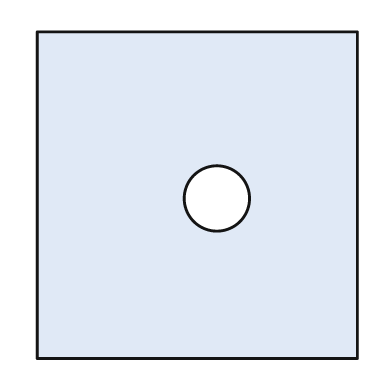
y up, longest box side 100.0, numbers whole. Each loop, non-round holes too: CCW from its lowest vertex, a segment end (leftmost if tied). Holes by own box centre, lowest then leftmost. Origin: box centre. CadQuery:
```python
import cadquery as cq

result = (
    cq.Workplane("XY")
    .moveTo(-49.0, -50.0)
    .lineTo(49.0, -50.0)
    .lineTo(49.0, 50.0)
    .lineTo(-49.0, 50.0)
    .close()
    .moveTo(6.0, -1.0)
    .circle(10.0)
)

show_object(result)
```